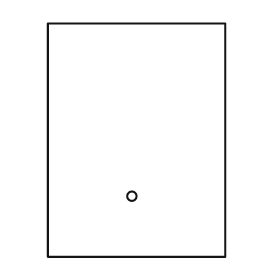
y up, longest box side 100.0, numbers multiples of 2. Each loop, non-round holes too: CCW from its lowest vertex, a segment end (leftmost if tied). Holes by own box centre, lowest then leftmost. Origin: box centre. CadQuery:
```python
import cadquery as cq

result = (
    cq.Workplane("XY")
    .moveTo(-38.0, -50.0)
    .lineTo(38.0, -50.0)
    .lineTo(38.0, 50.0)
    .lineTo(-38.0, 50.0)
    .close()
    .moveTo(-2.0, -24.0)
    .circle(2.0)
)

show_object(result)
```